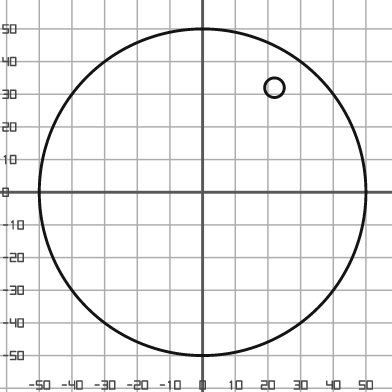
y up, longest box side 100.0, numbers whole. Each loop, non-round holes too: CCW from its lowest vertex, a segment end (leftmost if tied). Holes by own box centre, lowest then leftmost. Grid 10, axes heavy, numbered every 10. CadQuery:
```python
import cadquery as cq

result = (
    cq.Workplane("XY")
    .moveTo(0.0, 0.0)
    .circle(50.0)
    .moveTo(22.0, 32.0)
    .circle(3.0)
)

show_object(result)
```